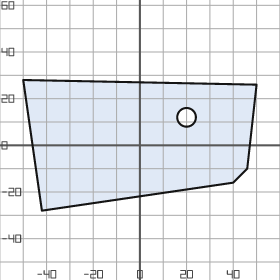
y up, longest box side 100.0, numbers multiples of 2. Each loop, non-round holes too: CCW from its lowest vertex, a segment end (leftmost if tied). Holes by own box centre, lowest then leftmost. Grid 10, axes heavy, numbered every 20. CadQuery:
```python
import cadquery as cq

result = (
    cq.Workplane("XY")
    .moveTo(-42.0, -28.0)
    .lineTo(40.0, -16.0)
    .lineTo(46.0, -10.0)
    .lineTo(50.0, 26.0)
    .lineTo(-50.0, 28.0)
    .close()
    .moveTo(20.0, 12.0)
    .circle(4.0)
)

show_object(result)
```